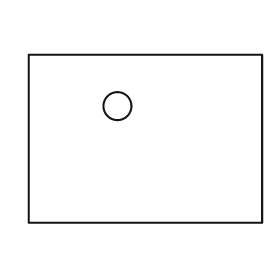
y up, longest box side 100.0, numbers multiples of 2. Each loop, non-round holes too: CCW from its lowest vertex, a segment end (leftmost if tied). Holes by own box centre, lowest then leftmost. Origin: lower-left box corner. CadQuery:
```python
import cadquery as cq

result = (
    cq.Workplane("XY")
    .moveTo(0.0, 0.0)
    .lineTo(100.0, 0.0)
    .lineTo(100.0, 72.0)
    .lineTo(0.0, 72.0)
    .close()
    .moveTo(38.0, 50.0)
    .circle(6.0)
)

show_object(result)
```